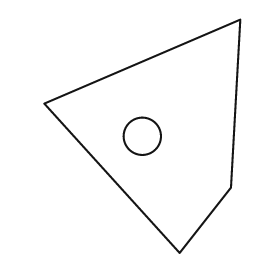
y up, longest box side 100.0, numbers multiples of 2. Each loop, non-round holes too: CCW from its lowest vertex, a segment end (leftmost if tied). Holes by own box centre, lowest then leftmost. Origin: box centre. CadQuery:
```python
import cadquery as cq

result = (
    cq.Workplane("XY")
    .moveTo(16.0, -50.0)
    .lineTo(38.0, -22.0)
    .lineTo(42.0, 50.0)
    .lineTo(-42.0, 14.0)
    .close()
    .moveTo(0.0, 0.0)
    .circle(8.0)
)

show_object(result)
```